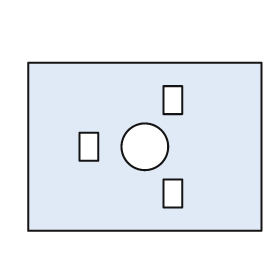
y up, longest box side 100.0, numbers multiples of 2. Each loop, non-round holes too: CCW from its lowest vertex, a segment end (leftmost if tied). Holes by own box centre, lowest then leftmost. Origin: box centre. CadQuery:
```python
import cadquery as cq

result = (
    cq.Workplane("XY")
    .moveTo(-50.0, -36.0)
    .lineTo(50.0, -36.0)
    .lineTo(50.0, 36.0)
    .lineTo(-50.0, 36.0)
    .close()
    .moveTo(8.0, -26.0)
    .lineTo(16.0, -26.0)
    .lineTo(16.0, -14.0)
    .lineTo(8.0, -14.0)
    .close()
    .moveTo(-28.0, -6.0)
    .lineTo(-20.0, -6.0)
    .lineTo(-20.0, 6.0)
    .lineTo(-28.0, 6.0)
    .close()
    .moveTo(0.0, 0.0)
    .circle(10.0)
    .moveTo(8.0, 14.0)
    .lineTo(16.0, 14.0)
    .lineTo(16.0, 26.0)
    .lineTo(8.0, 26.0)
    .close()
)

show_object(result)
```